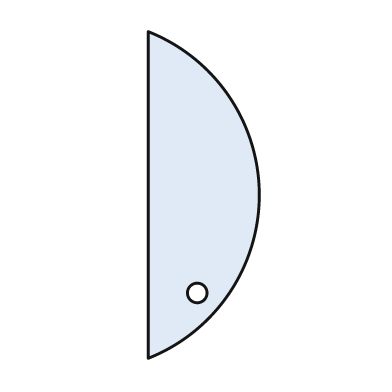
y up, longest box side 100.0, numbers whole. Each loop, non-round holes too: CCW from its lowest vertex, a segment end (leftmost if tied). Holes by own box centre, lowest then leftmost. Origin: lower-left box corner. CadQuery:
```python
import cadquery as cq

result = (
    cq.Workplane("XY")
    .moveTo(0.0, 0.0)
    .threePointArc((34.0, 50.0), (0.0, 100.0))
    .close()
    .moveTo(15.0, 20.0)
    .circle(3.0)
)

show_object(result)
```